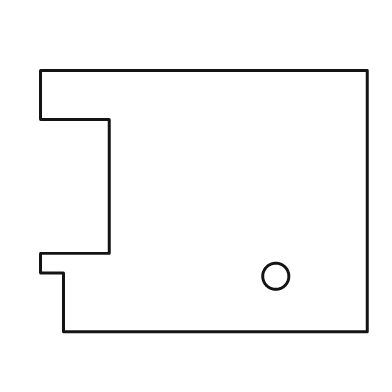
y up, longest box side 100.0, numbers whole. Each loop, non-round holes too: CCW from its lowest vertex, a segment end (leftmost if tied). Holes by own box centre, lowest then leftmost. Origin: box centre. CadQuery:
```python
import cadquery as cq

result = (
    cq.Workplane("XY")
    .moveTo(-43.0, -40.0)
    .lineTo(50.0, -40.0)
    .lineTo(50.0, 40.0)
    .lineTo(-50.0, 40.0)
    .lineTo(-50.0, 25.0)
    .lineTo(-29.0, 25.0)
    .lineTo(-29.0, -16.0)
    .lineTo(-50.0, -16.0)
    .lineTo(-50.0, -22.0)
    .lineTo(-43.0, -22.0)
    .close()
    .moveTo(22.0, -23.0)
    .circle(4.0)
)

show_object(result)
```